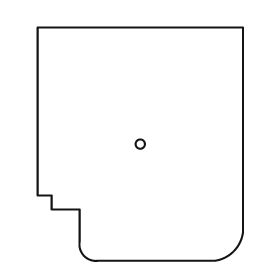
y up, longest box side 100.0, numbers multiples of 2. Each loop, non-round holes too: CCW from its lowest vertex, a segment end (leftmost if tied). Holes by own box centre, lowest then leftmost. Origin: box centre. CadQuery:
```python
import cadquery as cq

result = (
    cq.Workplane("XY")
    .moveTo(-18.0, -50.0)
    .lineTo(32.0, -50.0)
    .threePointArc((40.0, -46.0), (44.0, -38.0))
    .lineTo(44.0, 50.0)
    .lineTo(-44.0, 50.0)
    .lineTo(-44.0, -22.0)
    .lineTo(-38.0, -22.0)
    .lineTo(-38.0, -28.0)
    .lineTo(-26.0, -28.0)
    .lineTo(-26.0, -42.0)
    .threePointArc((-24.0, -48.0), (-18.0, -50.0))
    .close()
    .moveTo(0.0, 0.0)
    .circle(2.0)
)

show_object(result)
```